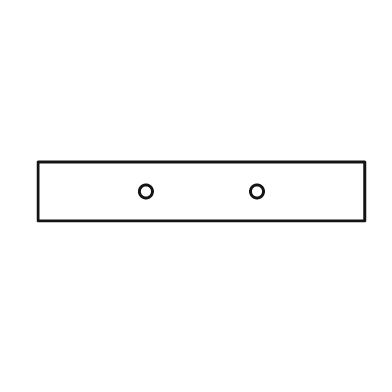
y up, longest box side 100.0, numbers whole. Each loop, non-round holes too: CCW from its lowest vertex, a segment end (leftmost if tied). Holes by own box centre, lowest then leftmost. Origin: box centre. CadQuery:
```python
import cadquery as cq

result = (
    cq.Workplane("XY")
    .moveTo(-50.0, -9.0)
    .lineTo(50.0, -9.0)
    .lineTo(50.0, 9.0)
    .lineTo(-50.0, 9.0)
    .close()
    .moveTo(-17.0, 0.0)
    .circle(2.0)
    .moveTo(17.0, 0.0)
    .circle(2.0)
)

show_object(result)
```